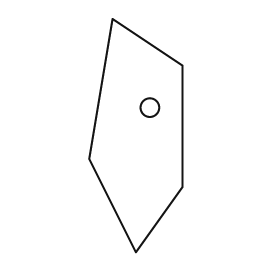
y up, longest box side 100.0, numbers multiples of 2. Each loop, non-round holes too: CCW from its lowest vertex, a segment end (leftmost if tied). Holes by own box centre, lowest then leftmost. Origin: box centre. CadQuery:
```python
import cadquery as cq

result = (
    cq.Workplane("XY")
    .moveTo(0.0, -50.0)
    .lineTo(20.0, -22.0)
    .lineTo(20.0, 30.0)
    .lineTo(-10.0, 50.0)
    .lineTo(-20.0, -10.0)
    .close()
    .moveTo(6.0, 12.0)
    .circle(4.0)
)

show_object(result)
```